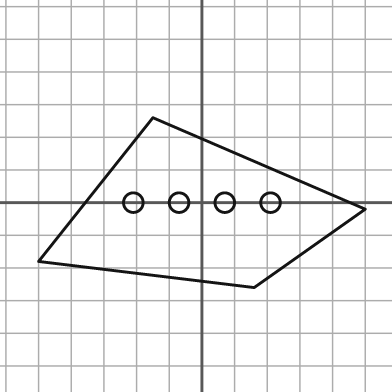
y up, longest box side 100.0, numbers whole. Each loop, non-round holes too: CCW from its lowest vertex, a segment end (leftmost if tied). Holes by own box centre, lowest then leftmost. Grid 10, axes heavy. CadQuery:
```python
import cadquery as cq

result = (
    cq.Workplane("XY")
    .moveTo(16.0, -26.0)
    .lineTo(50.0, -2.0)
    .lineTo(-15.0, 26.0)
    .lineTo(-50.0, -18.0)
    .close()
    .moveTo(-21.0, 0.0)
    .circle(3.0)
    .moveTo(-7.0, 0.0)
    .circle(3.0)
    .moveTo(7.0, 0.0)
    .circle(3.0)
    .moveTo(21.0, 0.0)
    .circle(3.0)
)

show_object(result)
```